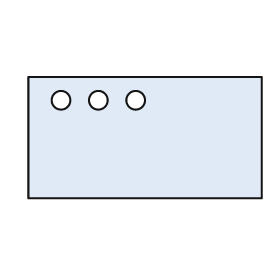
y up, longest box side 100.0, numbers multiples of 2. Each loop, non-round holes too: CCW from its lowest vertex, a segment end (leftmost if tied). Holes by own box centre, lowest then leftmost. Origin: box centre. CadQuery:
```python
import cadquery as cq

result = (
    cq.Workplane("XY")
    .moveTo(-50.0, -26.0)
    .lineTo(50.0, -26.0)
    .lineTo(50.0, 26.0)
    .lineTo(-50.0, 26.0)
    .close()
    .moveTo(-36.0, 16.0)
    .circle(4.0)
    .moveTo(-20.0, 16.0)
    .circle(4.0)
    .moveTo(-4.0, 16.0)
    .circle(4.0)
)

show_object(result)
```